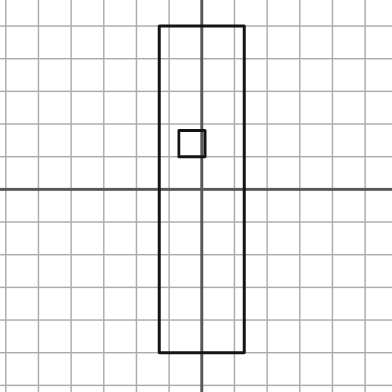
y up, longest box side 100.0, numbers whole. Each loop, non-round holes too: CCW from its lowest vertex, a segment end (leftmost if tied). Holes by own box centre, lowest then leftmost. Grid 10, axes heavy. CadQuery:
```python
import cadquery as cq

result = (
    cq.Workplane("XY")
    .moveTo(-13.0, -50.0)
    .lineTo(13.0, -50.0)
    .lineTo(13.0, 50.0)
    .lineTo(-13.0, 50.0)
    .close()
    .moveTo(-7.0, 10.0)
    .lineTo(1.0, 10.0)
    .lineTo(1.0, 18.0)
    .lineTo(-7.0, 18.0)
    .close()
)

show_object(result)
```